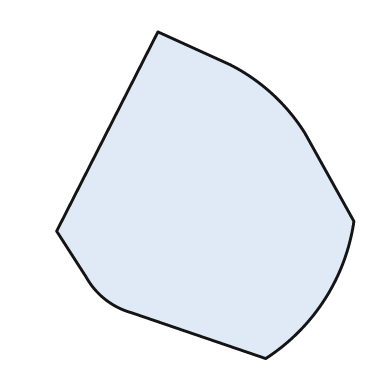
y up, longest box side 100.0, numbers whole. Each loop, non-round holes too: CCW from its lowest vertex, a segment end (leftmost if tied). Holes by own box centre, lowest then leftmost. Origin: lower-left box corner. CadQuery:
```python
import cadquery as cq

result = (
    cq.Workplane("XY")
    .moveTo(64.0, 0.0)
    .threePointArc((82.0, 18.0), (91.0, 42.0))
    .lineTo(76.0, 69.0)
    .threePointArc((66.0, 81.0), (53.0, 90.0))
    .lineTo(31.0, 100.0)
    .lineTo(0.0, 39.0)
    .lineTo(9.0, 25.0)
    .threePointArc((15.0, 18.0), (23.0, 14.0))
    .close()
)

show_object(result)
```